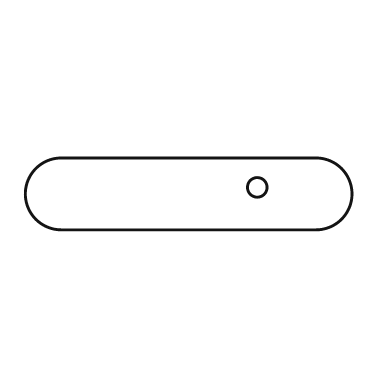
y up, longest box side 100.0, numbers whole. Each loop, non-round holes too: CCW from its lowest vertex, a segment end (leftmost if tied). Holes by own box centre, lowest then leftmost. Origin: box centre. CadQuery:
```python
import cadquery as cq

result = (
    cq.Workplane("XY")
    .moveTo(-39.0, -11.0)
    .lineTo(39.0, -11.0)
    .threePointArc((50.0, 0.0), (39.0, 11.0))
    .lineTo(-39.0, 11.0)
    .threePointArc((-50.0, 0.0), (-39.0, -11.0))
    .close()
    .moveTo(21.0, 2.0)
    .circle(3.0)
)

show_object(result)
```